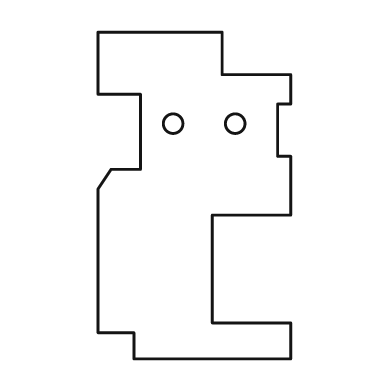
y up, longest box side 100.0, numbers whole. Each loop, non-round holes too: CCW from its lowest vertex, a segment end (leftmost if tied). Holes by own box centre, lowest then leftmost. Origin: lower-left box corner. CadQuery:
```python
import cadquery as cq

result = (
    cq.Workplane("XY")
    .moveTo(11.0, 0.0)
    .lineTo(59.0, 0.0)
    .lineTo(59.0, 11.0)
    .lineTo(35.0, 11.0)
    .lineTo(35.0, 44.0)
    .lineTo(59.0, 44.0)
    .lineTo(59.0, 62.0)
    .lineTo(55.0, 62.0)
    .lineTo(55.0, 78.0)
    .lineTo(59.0, 78.0)
    .lineTo(59.0, 87.0)
    .lineTo(38.0, 87.0)
    .lineTo(38.0, 100.0)
    .lineTo(0.0, 100.0)
    .lineTo(0.0, 81.0)
    .lineTo(13.0, 81.0)
    .lineTo(13.0, 58.0)
    .lineTo(4.0, 58.0)
    .lineTo(0.0, 52.0)
    .lineTo(0.0, 8.0)
    .lineTo(11.0, 8.0)
    .close()
    .moveTo(23.0, 72.0)
    .circle(3.0)
    .moveTo(42.0, 72.0)
    .circle(3.0)
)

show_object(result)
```